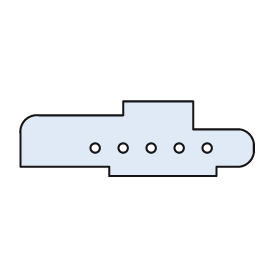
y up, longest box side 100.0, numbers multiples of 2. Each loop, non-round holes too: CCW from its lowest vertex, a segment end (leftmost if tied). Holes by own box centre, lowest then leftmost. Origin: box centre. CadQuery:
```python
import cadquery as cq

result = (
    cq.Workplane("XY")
    .moveTo(-12.0, -16.0)
    .lineTo(34.0, -16.0)
    .lineTo(34.0, -12.0)
    .lineTo(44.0, -12.0)
    .threePointArc((48.0, -10.0), (50.0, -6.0))
    .lineTo(50.0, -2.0)
    .threePointArc((48.0, 2.0), (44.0, 4.0))
    .lineTo(24.0, 4.0)
    .lineTo(24.0, 16.0)
    .lineTo(-6.0, 16.0)
    .lineTo(-6.0, 10.0)
    .lineTo(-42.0, 10.0)
    .threePointArc((-48.0, 8.0), (-50.0, 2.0))
    .lineTo(-50.0, -12.0)
    .lineTo(-12.0, -12.0)
    .close()
    .moveTo(-18.0, -4.0)
    .circle(2.0)
    .moveTo(-6.0, -4.0)
    .circle(2.0)
    .moveTo(6.0, -4.0)
    .circle(2.0)
    .moveTo(18.0, -4.0)
    .circle(2.0)
    .moveTo(30.0, -4.0)
    .circle(2.0)
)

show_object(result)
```